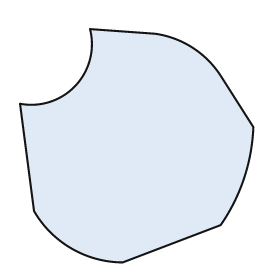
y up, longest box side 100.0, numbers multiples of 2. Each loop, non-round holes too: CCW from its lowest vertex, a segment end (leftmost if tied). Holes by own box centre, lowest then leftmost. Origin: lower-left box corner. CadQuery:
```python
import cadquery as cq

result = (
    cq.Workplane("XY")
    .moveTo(44.0, 0.0)
    .lineTo(86.0, 16.0)
    .threePointArc((96.0, 36.0), (100.0, 58.0))
    .lineTo(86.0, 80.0)
    .threePointArc((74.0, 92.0), (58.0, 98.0))
    .lineTo(30.0, 100.0)
    .threePointArc((24.0, 76.0), (0.0, 68.0))
    .lineTo(6.0, 22.0)
    .threePointArc((22.0, 6.0), (44.0, 0.0))
    .close()
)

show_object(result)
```